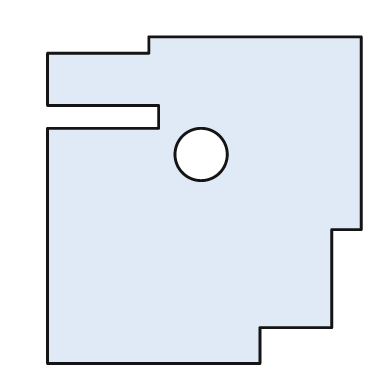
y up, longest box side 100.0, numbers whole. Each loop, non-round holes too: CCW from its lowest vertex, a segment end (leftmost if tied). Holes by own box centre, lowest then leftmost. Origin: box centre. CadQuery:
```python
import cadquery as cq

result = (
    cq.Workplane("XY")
    .moveTo(-48.0, -50.0)
    .lineTo(17.0, -50.0)
    .lineTo(17.0, -39.0)
    .lineTo(39.0, -39.0)
    .lineTo(39.0, -9.0)
    .lineTo(48.0, -9.0)
    .lineTo(48.0, 50.0)
    .lineTo(-17.0, 50.0)
    .lineTo(-17.0, 45.0)
    .lineTo(-48.0, 45.0)
    .lineTo(-48.0, 29.0)
    .lineTo(-14.0, 29.0)
    .lineTo(-14.0, 22.0)
    .lineTo(-48.0, 22.0)
    .close()
    .moveTo(-1.0, 14.0)
    .circle(8.0)
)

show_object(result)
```